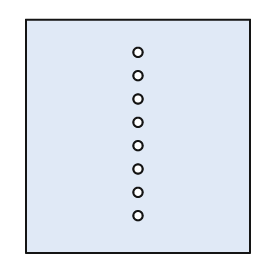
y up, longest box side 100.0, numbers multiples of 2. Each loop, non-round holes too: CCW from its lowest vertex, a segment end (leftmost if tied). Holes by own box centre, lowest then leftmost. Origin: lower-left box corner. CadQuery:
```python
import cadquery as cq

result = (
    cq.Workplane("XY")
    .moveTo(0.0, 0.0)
    .lineTo(96.0, 0.0)
    .lineTo(96.0, 100.0)
    .lineTo(0.0, 100.0)
    .close()
    .moveTo(48.0, 16.0)
    .circle(2.0)
    .moveTo(48.0, 26.0)
    .circle(2.0)
    .moveTo(48.0, 36.0)
    .circle(2.0)
    .moveTo(48.0, 46.0)
    .circle(2.0)
    .moveTo(48.0, 56.0)
    .circle(2.0)
    .moveTo(48.0, 66.0)
    .circle(2.0)
    .moveTo(48.0, 76.0)
    .circle(2.0)
    .moveTo(48.0, 86.0)
    .circle(2.0)
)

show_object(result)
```